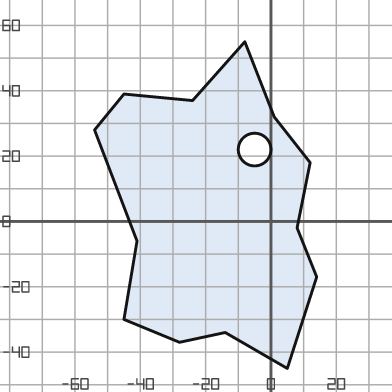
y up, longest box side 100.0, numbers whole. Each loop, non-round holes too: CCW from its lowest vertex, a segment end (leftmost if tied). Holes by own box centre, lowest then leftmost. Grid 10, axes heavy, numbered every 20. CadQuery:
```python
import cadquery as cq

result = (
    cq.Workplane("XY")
    .moveTo(5.0, -45.0)
    .lineTo(14.0, -17.0)
    .lineTo(8.0, -2.0)
    .lineTo(12.0, 18.0)
    .lineTo(1.0, 32.0)
    .lineTo(-8.0, 55.0)
    .lineTo(-24.0, 37.0)
    .lineTo(-45.0, 39.0)
    .lineTo(-54.0, 28.0)
    .lineTo(-41.0, -6.0)
    .lineTo(-45.0, -30.0)
    .lineTo(-28.0, -37.0)
    .lineTo(-14.0, -34.0)
    .close()
    .moveTo(-5.0, 22.0)
    .circle(5.0)
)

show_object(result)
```